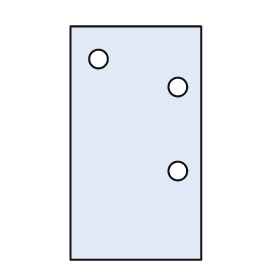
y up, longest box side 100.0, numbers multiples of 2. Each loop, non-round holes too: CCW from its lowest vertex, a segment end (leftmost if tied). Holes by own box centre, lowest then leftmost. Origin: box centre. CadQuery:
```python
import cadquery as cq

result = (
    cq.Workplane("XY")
    .moveTo(-28.0, -50.0)
    .lineTo(28.0, -50.0)
    .lineTo(28.0, 50.0)
    .lineTo(-28.0, 50.0)
    .close()
    .moveTo(18.0, -12.0)
    .circle(4.0)
    .moveTo(18.0, 24.0)
    .circle(4.0)
    .moveTo(-16.0, 36.0)
    .circle(4.0)
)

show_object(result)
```